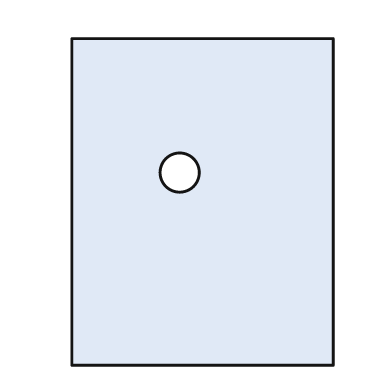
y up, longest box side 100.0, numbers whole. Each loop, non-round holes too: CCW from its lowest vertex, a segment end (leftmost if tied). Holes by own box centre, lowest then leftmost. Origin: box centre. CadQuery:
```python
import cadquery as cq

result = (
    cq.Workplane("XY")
    .moveTo(-40.0, -50.0)
    .lineTo(40.0, -50.0)
    .lineTo(40.0, 50.0)
    .lineTo(-40.0, 50.0)
    .close()
    .moveTo(-7.0, 9.0)
    .circle(6.0)
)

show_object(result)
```